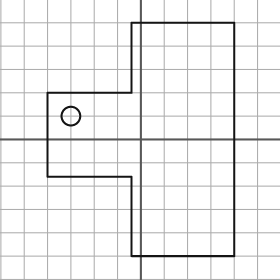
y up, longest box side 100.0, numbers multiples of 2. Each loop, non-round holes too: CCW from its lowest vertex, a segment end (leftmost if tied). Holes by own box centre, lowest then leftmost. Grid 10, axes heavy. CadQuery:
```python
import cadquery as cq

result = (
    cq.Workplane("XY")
    .moveTo(-4.0, -50.0)
    .lineTo(40.0, -50.0)
    .lineTo(40.0, 50.0)
    .lineTo(-4.0, 50.0)
    .lineTo(-4.0, 20.0)
    .lineTo(-40.0, 20.0)
    .lineTo(-40.0, -16.0)
    .lineTo(-4.0, -16.0)
    .close()
    .moveTo(-30.0, 10.0)
    .circle(4.0)
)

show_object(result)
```